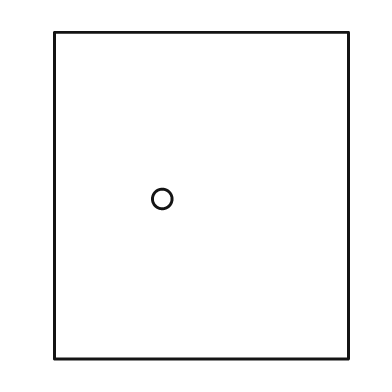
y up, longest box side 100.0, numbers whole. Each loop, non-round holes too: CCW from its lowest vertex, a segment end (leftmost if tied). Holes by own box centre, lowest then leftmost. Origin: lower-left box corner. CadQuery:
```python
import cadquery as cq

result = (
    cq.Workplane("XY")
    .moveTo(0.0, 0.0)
    .lineTo(90.0, 0.0)
    .lineTo(90.0, 100.0)
    .lineTo(0.0, 100.0)
    .close()
    .moveTo(33.0, 49.0)
    .circle(3.0)
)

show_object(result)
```